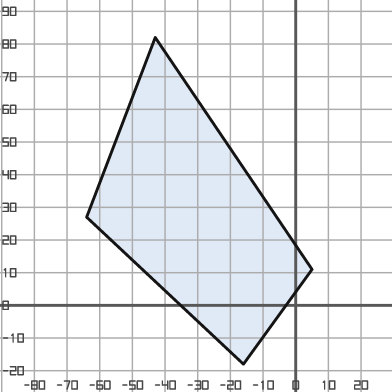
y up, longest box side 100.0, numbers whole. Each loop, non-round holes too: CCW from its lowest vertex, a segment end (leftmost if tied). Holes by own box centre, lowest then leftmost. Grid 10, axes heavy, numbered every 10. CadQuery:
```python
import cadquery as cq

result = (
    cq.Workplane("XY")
    .moveTo(-16.0, -18.0)
    .lineTo(5.0, 11.0)
    .lineTo(-43.0, 82.0)
    .lineTo(-64.0, 27.0)
    .close()
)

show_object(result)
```